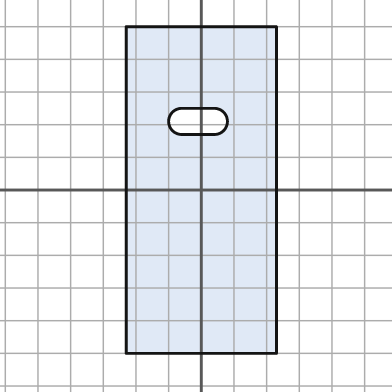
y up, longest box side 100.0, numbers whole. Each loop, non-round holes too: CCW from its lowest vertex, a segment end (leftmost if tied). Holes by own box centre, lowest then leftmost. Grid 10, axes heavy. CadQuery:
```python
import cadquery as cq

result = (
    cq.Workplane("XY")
    .moveTo(-23.0, -50.0)
    .lineTo(23.0, -50.0)
    .lineTo(23.0, 50.0)
    .lineTo(-23.0, 50.0)
    .close()
    .moveTo(-6.0, 17.0)
    .lineTo(4.0, 17.0)
    .threePointArc((8.0, 21.0), (4.0, 25.0))
    .lineTo(-6.0, 25.0)
    .threePointArc((-10.0, 21.0), (-6.0, 17.0))
    .close()
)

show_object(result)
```